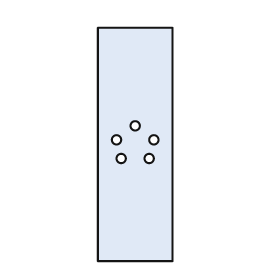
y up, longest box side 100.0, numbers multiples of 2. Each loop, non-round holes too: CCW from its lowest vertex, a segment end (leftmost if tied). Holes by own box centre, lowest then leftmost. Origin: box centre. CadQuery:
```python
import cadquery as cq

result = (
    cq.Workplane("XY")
    .moveTo(-16.0, -50.0)
    .lineTo(16.0, -50.0)
    .lineTo(16.0, 50.0)
    .lineTo(-16.0, 50.0)
    .close()
    .moveTo(-6.0, -6.0)
    .circle(2.0)
    .moveTo(6.0, -6.0)
    .circle(2.0)
    .moveTo(-8.0, 2.0)
    .circle(2.0)
    .moveTo(8.0, 2.0)
    .circle(2.0)
    .moveTo(0.0, 8.0)
    .circle(2.0)
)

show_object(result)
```